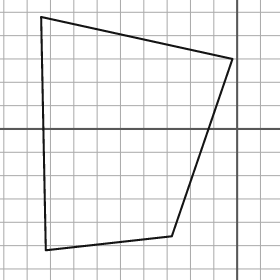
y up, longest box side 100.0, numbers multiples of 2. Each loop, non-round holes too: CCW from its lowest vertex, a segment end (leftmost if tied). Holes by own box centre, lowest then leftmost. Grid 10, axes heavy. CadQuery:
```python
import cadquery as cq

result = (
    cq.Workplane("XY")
    .moveTo(-82.0, -52.0)
    .lineTo(-28.0, -46.0)
    .lineTo(-2.0, 30.0)
    .lineTo(-84.0, 48.0)
    .close()
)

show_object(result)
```